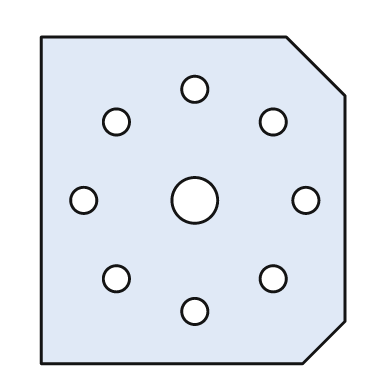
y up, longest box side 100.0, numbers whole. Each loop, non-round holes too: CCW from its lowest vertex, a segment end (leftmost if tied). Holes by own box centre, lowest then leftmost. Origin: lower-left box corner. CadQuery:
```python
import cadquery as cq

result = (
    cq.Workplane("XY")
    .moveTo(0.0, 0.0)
    .lineTo(80.0, 0.0)
    .lineTo(93.0, 13.0)
    .lineTo(93.0, 82.0)
    .lineTo(75.0, 100.0)
    .lineTo(0.0, 100.0)
    .close()
    .moveTo(47.0, 16.0)
    .circle(4.0)
    .moveTo(23.0, 26.0)
    .circle(4.0)
    .moveTo(71.0, 26.0)
    .circle(4.0)
    .moveTo(13.0, 50.0)
    .circle(4.0)
    .moveTo(47.0, 50.0)
    .circle(7.0)
    .moveTo(81.0, 50.0)
    .circle(4.0)
    .moveTo(23.0, 74.0)
    .circle(4.0)
    .moveTo(71.0, 74.0)
    .circle(4.0)
    .moveTo(47.0, 84.0)
    .circle(4.0)
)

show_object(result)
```